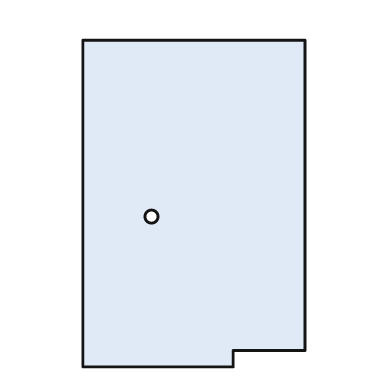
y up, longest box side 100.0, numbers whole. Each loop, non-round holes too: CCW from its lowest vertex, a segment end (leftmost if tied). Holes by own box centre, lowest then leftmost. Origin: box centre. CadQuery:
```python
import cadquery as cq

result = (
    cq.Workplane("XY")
    .moveTo(-34.0, -50.0)
    .lineTo(12.0, -50.0)
    .lineTo(12.0, -45.0)
    .lineTo(34.0, -45.0)
    .lineTo(34.0, 50.0)
    .lineTo(-34.0, 50.0)
    .close()
    .moveTo(-13.0, -4.0)
    .circle(2.0)
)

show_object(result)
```